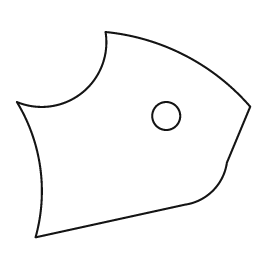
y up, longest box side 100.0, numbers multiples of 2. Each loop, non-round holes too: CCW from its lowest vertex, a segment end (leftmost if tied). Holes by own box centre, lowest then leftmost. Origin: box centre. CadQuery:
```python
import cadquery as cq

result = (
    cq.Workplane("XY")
    .moveTo(-42.0, -44.0)
    .lineTo(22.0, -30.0)
    .threePointArc((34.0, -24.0), (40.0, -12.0))
    .lineTo(50.0, 12.0)
    .threePointArc((22.0, 34.0), (-12.0, 44.0))
    .threePointArc((-22.0, 18.0), (-50.0, 14.0))
    .threePointArc((-40.0, -14.0), (-42.0, -44.0))
    .close()
    .moveTo(14.0, 8.0)
    .circle(6.0)
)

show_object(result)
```